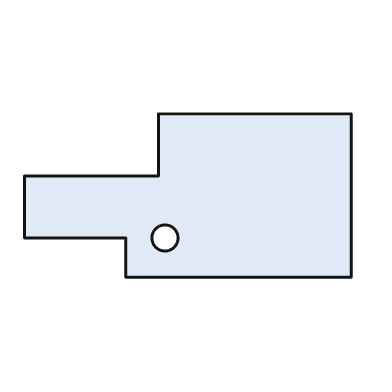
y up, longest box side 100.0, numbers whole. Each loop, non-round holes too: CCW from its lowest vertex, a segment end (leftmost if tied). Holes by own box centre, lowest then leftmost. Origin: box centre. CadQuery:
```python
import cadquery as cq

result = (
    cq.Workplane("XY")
    .moveTo(-19.0, -25.0)
    .lineTo(50.0, -25.0)
    .lineTo(50.0, 25.0)
    .lineTo(-9.0, 25.0)
    .lineTo(-9.0, 6.0)
    .lineTo(-50.0, 6.0)
    .lineTo(-50.0, -13.0)
    .lineTo(-19.0, -13.0)
    .close()
    .moveTo(-7.0, -13.0)
    .circle(4.0)
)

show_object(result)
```